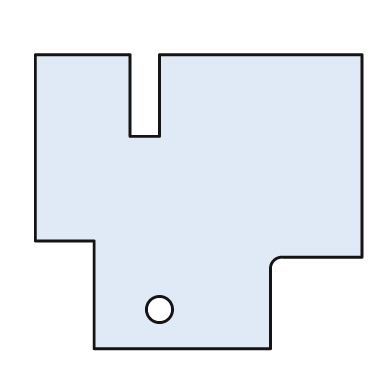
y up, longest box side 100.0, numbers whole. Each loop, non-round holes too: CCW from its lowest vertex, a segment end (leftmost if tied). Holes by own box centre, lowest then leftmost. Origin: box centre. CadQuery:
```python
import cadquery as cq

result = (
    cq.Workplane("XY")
    .moveTo(-32.0, -45.0)
    .lineTo(22.0, -45.0)
    .lineTo(22.0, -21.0)
    .threePointArc((23.0, -18.0), (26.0, -17.0))
    .lineTo(50.0, -17.0)
    .lineTo(50.0, 45.0)
    .lineTo(-12.0, 45.0)
    .lineTo(-12.0, 20.0)
    .lineTo(-21.0, 20.0)
    .lineTo(-21.0, 45.0)
    .lineTo(-50.0, 45.0)
    .lineTo(-50.0, -12.0)
    .lineTo(-32.0, -12.0)
    .close()
    .moveTo(-12.0, -33.0)
    .circle(4.0)
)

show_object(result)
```